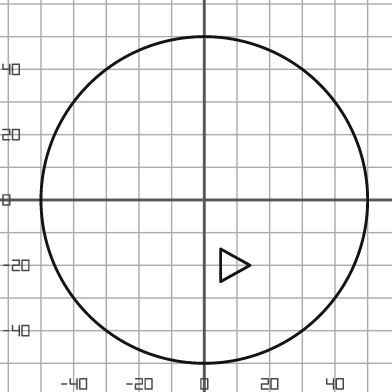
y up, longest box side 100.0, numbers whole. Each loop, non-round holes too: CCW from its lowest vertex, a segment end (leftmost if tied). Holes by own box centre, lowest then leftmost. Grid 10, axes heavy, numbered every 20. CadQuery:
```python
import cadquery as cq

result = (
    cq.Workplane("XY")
    .moveTo(0.0, 0.0)
    .circle(50.0)
    .moveTo(5.0, -25.0)
    .lineTo(14.0, -20.0)
    .lineTo(5.0, -15.0)
    .close()
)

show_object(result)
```